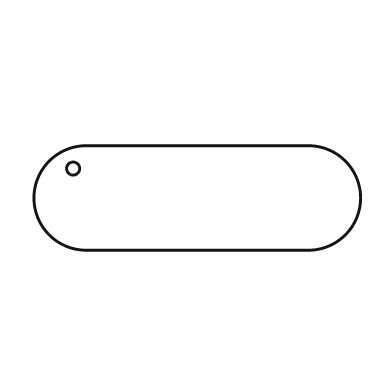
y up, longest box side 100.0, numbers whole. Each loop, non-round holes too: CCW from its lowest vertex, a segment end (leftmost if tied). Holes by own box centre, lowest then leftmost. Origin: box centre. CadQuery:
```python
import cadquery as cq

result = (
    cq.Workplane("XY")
    .moveTo(-34.0, -16.0)
    .lineTo(34.0, -16.0)
    .threePointArc((50.0, 0.0), (34.0, 16.0))
    .lineTo(-34.0, 16.0)
    .threePointArc((-50.0, 0.0), (-34.0, -16.0))
    .close()
    .moveTo(-38.0, 9.0)
    .circle(2.0)
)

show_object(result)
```